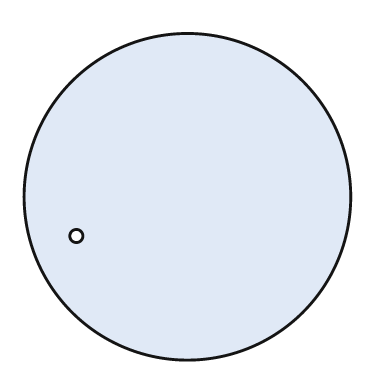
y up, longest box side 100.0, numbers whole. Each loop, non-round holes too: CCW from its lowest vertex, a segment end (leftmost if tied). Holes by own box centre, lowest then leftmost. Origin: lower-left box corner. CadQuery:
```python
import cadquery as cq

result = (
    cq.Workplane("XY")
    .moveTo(50.0, 50.0)
    .circle(50.0)
    .moveTo(16.0, 38.0)
    .circle(2.0)
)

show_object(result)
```